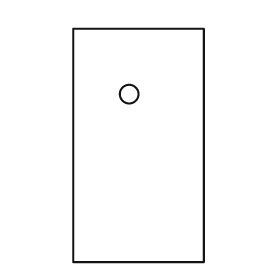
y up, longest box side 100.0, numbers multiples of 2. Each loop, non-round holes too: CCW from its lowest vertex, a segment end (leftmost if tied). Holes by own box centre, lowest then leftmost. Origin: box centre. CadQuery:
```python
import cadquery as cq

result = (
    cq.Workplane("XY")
    .moveTo(-28.0, -50.0)
    .lineTo(28.0, -50.0)
    .lineTo(28.0, 50.0)
    .lineTo(-28.0, 50.0)
    .close()
    .moveTo(-4.0, 22.0)
    .circle(4.0)
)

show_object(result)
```